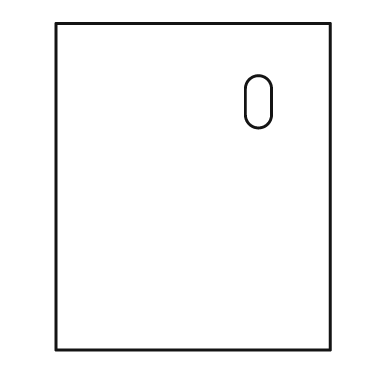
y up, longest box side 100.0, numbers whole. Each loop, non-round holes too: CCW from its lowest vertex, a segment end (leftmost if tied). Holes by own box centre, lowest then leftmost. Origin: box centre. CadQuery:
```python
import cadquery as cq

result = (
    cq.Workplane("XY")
    .moveTo(-42.0, -50.0)
    .lineTo(42.0, -50.0)
    .lineTo(42.0, 50.0)
    .lineTo(-42.0, 50.0)
    .close()
    .moveTo(16.0, 22.0)
    .threePointArc((20.0, 18.0), (24.0, 22.0))
    .lineTo(24.0, 30.0)
    .threePointArc((20.0, 34.0), (16.0, 30.0))
    .close()
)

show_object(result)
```